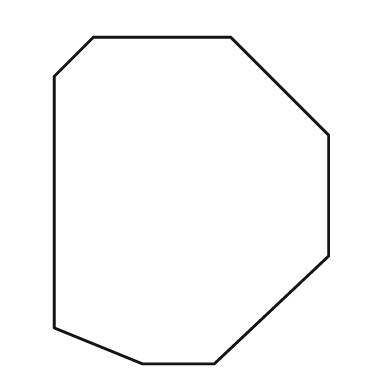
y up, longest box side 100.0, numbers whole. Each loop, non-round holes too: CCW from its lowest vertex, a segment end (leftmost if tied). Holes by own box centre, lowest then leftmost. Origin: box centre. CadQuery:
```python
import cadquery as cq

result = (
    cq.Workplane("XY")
    .moveTo(-15.0, -50.0)
    .lineTo(7.0, -50.0)
    .lineTo(42.0, -17.0)
    .lineTo(42.0, 20.0)
    .lineTo(12.0, 50.0)
    .lineTo(-30.0, 50.0)
    .lineTo(-42.0, 38.0)
    .lineTo(-42.0, -39.0)
    .close()
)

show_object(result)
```